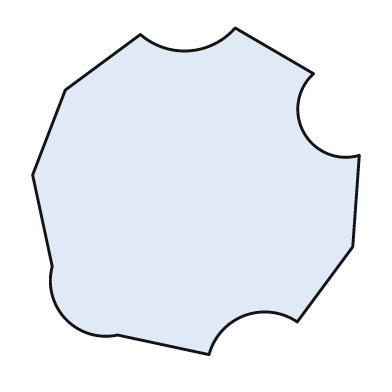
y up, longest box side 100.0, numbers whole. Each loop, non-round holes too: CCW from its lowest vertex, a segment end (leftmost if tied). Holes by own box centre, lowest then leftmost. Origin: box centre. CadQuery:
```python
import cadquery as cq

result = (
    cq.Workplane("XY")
    .moveTo(4.0, -50.0)
    .threePointArc((15.0, -38.0), (31.0, -40.0))
    .lineTo(48.0, -17.0)
    .lineTo(50.0, 11.0)
    .threePointArc((33.0, 18.0), (36.0, 36.0))
    .lineTo(12.0, 50.0)
    .threePointArc((-2.0, 43.0), (-17.0, 48.0))
    .lineTo(-40.0, 31.0)
    .lineTo(-50.0, 5.0)
    .lineTo(-44.0, -23.0)
    .threePointArc((-40.0, -39.0), (-24.0, -44.0))
    .close()
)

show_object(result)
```